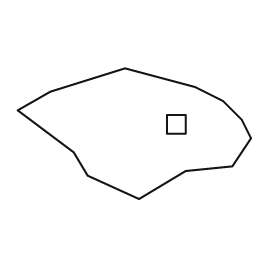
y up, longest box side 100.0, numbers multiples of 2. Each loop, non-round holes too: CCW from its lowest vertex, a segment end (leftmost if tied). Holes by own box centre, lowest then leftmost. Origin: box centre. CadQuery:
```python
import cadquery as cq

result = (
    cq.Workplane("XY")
    .moveTo(2.0, -28.0)
    .lineTo(22.0, -16.0)
    .lineTo(42.0, -14.0)
    .lineTo(50.0, -2.0)
    .lineTo(46.0, 6.0)
    .lineTo(38.0, 14.0)
    .lineTo(26.0, 20.0)
    .lineTo(-4.0, 28.0)
    .lineTo(-36.0, 18.0)
    .lineTo(-50.0, 10.0)
    .lineTo(-26.0, -8.0)
    .lineTo(-20.0, -18.0)
    .close()
    .moveTo(14.0, 0.0)
    .lineTo(22.0, 0.0)
    .lineTo(22.0, 8.0)
    .lineTo(14.0, 8.0)
    .close()
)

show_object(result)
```